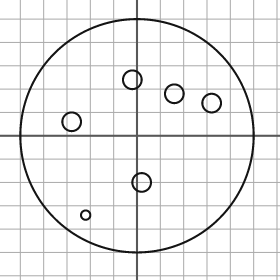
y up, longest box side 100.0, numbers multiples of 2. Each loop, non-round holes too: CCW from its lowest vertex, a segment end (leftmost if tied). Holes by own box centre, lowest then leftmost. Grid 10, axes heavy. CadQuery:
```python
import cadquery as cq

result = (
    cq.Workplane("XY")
    .moveTo(0.0, 0.0)
    .circle(50.0)
    .moveTo(-22.0, -34.0)
    .circle(2.0)
    .moveTo(2.0, -20.0)
    .circle(4.0)
    .moveTo(-28.0, 6.0)
    .circle(4.0)
    .moveTo(32.0, 14.0)
    .circle(4.0)
    .moveTo(16.0, 18.0)
    .circle(4.0)
    .moveTo(-2.0, 24.0)
    .circle(4.0)
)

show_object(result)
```